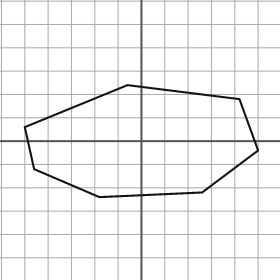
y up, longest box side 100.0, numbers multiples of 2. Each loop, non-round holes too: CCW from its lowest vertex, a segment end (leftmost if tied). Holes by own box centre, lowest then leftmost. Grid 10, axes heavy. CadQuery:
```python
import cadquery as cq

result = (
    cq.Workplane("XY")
    .moveTo(-18.0, -24.0)
    .lineTo(26.0, -22.0)
    .lineTo(50.0, -4.0)
    .lineTo(42.0, 18.0)
    .lineTo(-6.0, 24.0)
    .lineTo(-50.0, 6.0)
    .lineTo(-46.0, -12.0)
    .close()
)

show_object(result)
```